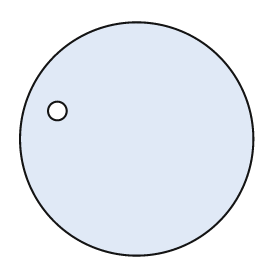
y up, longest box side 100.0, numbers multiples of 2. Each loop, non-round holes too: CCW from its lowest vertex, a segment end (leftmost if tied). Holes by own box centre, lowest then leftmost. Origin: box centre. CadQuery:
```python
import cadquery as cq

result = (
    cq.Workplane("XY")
    .moveTo(0.0, 0.0)
    .circle(50.0)
    .moveTo(-34.0, 12.0)
    .circle(4.0)
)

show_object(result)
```